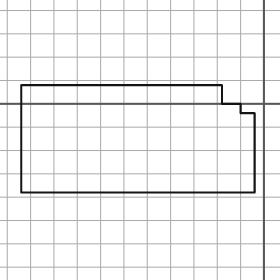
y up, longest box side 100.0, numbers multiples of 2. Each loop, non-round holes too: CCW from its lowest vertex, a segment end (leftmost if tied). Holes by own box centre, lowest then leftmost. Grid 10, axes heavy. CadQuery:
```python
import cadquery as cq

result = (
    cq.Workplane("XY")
    .moveTo(-104.0, -38.0)
    .lineTo(-4.0, -38.0)
    .lineTo(-4.0, -4.0)
    .lineTo(-10.0, -4.0)
    .lineTo(-10.0, 0.0)
    .lineTo(-18.0, 0.0)
    .lineTo(-18.0, 8.0)
    .lineTo(-104.0, 8.0)
    .close()
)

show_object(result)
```